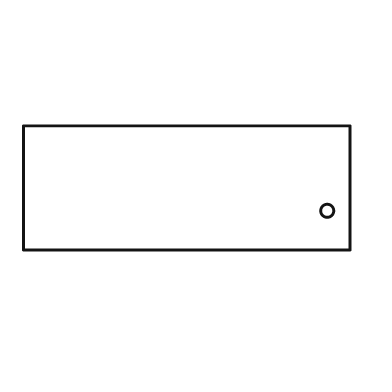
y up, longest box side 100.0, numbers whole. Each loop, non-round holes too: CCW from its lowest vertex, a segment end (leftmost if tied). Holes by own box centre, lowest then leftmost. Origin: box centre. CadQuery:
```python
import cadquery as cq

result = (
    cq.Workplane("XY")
    .moveTo(-50.0, -19.0)
    .lineTo(50.0, -19.0)
    .lineTo(50.0, 19.0)
    .lineTo(-50.0, 19.0)
    .close()
    .moveTo(43.0, -7.0)
    .circle(2.0)
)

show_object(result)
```